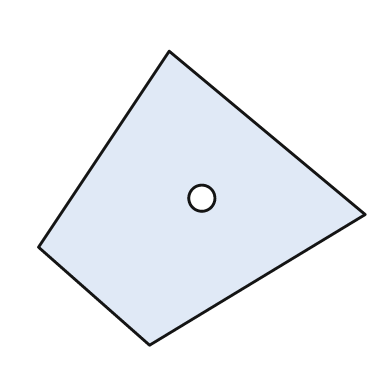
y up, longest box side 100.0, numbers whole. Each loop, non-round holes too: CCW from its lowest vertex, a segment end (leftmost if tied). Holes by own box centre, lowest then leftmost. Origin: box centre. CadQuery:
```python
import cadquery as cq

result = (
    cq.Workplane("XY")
    .moveTo(-16.0, -45.0)
    .lineTo(50.0, -5.0)
    .lineTo(-10.0, 45.0)
    .lineTo(-50.0, -15.0)
    .close()
    .moveTo(0.0, 0.0)
    .circle(4.0)
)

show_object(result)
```